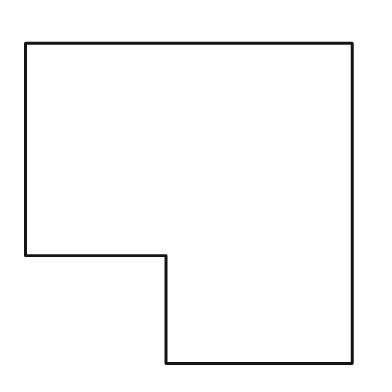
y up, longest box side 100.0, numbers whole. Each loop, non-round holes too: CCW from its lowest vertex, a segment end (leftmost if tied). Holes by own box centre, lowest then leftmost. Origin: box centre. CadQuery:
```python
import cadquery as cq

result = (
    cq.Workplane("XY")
    .moveTo(-7.0, -49.0)
    .lineTo(50.0, -49.0)
    .lineTo(50.0, 49.0)
    .lineTo(-50.0, 49.0)
    .lineTo(-50.0, -16.0)
    .lineTo(-7.0, -16.0)
    .close()
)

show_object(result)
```